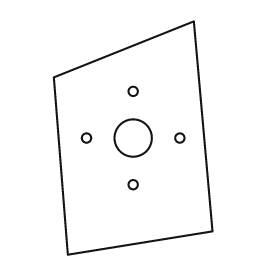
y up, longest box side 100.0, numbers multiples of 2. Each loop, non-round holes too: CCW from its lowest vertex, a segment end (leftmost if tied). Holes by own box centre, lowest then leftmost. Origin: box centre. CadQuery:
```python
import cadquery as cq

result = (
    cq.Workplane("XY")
    .moveTo(-28.0, -50.0)
    .lineTo(34.0, -40.0)
    .lineTo(26.0, 50.0)
    .lineTo(-34.0, 26.0)
    .close()
    .moveTo(0.0, -20.0)
    .circle(2.0)
    .moveTo(-20.0, 0.0)
    .circle(2.0)
    .moveTo(0.0, 0.0)
    .circle(8.0)
    .moveTo(20.0, 0.0)
    .circle(2.0)
    .moveTo(0.0, 20.0)
    .circle(2.0)
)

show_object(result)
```